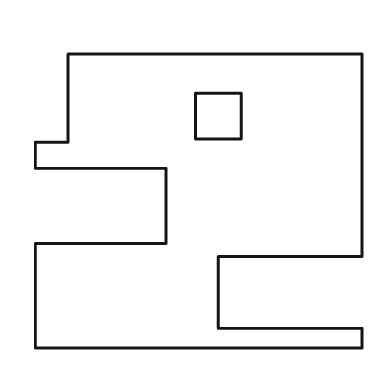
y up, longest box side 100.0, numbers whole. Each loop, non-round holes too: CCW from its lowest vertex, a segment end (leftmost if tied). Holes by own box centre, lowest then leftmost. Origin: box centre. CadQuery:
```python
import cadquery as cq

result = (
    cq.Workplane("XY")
    .moveTo(-50.0, -45.0)
    .lineTo(50.0, -45.0)
    .lineTo(50.0, -39.0)
    .lineTo(6.0, -39.0)
    .lineTo(6.0, -17.0)
    .lineTo(50.0, -17.0)
    .lineTo(50.0, 45.0)
    .lineTo(-40.0, 45.0)
    .lineTo(-40.0, 18.0)
    .lineTo(-50.0, 18.0)
    .lineTo(-50.0, 10.0)
    .lineTo(-10.0, 10.0)
    .lineTo(-10.0, -13.0)
    .lineTo(-50.0, -13.0)
    .close()
    .moveTo(-1.0, 19.0)
    .lineTo(13.0, 19.0)
    .lineTo(13.0, 33.0)
    .lineTo(-1.0, 33.0)
    .close()
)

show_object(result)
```